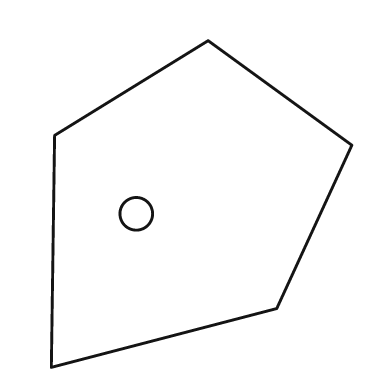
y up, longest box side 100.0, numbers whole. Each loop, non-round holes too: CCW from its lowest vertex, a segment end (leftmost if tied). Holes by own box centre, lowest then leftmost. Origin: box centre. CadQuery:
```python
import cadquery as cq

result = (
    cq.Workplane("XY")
    .moveTo(-46.0, -50.0)
    .lineTo(23.0, -32.0)
    .lineTo(46.0, 18.0)
    .lineTo(2.0, 50.0)
    .lineTo(-45.0, 21.0)
    .close()
    .moveTo(-20.0, -3.0)
    .circle(5.0)
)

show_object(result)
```